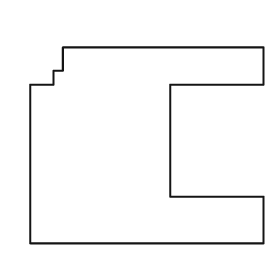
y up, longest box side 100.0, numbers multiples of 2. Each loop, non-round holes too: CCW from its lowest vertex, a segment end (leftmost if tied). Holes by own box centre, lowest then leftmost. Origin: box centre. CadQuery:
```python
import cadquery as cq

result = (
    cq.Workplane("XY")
    .moveTo(-50.0, -42.0)
    .lineTo(50.0, -42.0)
    .lineTo(50.0, -22.0)
    .lineTo(10.0, -22.0)
    .lineTo(10.0, 26.0)
    .lineTo(50.0, 26.0)
    .lineTo(50.0, 42.0)
    .lineTo(-36.0, 42.0)
    .lineTo(-36.0, 32.0)
    .lineTo(-40.0, 32.0)
    .lineTo(-40.0, 26.0)
    .lineTo(-50.0, 26.0)
    .close()
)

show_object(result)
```